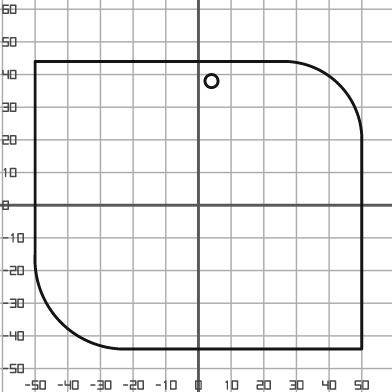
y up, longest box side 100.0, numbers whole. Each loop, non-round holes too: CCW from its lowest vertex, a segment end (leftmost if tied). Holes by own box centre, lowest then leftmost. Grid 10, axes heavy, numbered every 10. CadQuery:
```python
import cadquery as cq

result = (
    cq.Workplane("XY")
    .moveTo(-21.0, -44.0)
    .lineTo(50.0, -44.0)
    .lineTo(50.0, 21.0)
    .threePointArc((43.0, 37.0), (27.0, 44.0))
    .lineTo(-50.0, 44.0)
    .lineTo(-50.0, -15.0)
    .threePointArc((-42.0, -36.0), (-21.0, -44.0))
    .close()
    .moveTo(4.0, 38.0)
    .circle(2.0)
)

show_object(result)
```